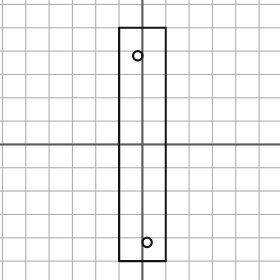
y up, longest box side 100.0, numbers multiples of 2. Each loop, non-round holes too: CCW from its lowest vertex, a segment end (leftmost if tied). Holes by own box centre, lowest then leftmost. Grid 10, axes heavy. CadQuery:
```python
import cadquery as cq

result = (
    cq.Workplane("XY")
    .moveTo(-10.0, -50.0)
    .lineTo(10.0, -50.0)
    .lineTo(10.0, 50.0)
    .lineTo(-10.0, 50.0)
    .close()
    .moveTo(2.0, -42.0)
    .circle(2.0)
    .moveTo(-2.0, 38.0)
    .circle(2.0)
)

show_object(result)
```